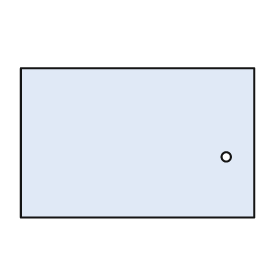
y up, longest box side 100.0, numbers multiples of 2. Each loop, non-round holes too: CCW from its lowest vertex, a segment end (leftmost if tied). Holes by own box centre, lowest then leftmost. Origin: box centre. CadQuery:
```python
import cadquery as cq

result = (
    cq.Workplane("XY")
    .moveTo(-50.0, -32.0)
    .lineTo(50.0, -32.0)
    .lineTo(50.0, 32.0)
    .lineTo(-50.0, 32.0)
    .close()
    .moveTo(38.0, -6.0)
    .circle(2.0)
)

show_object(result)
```